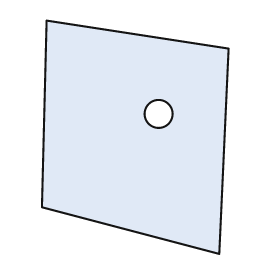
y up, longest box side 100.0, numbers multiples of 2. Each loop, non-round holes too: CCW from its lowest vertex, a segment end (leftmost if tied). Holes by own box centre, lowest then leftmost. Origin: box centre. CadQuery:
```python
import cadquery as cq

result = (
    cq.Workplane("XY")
    .moveTo(36.0, -50.0)
    .lineTo(40.0, 38.0)
    .lineTo(-38.0, 50.0)
    .lineTo(-40.0, -30.0)
    .close()
    .moveTo(10.0, 10.0)
    .circle(6.0)
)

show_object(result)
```